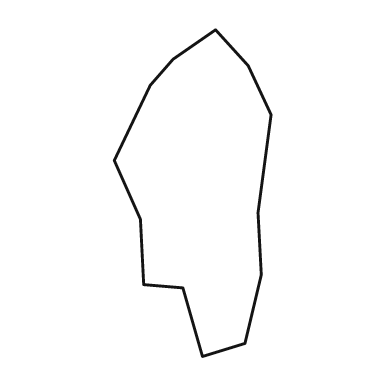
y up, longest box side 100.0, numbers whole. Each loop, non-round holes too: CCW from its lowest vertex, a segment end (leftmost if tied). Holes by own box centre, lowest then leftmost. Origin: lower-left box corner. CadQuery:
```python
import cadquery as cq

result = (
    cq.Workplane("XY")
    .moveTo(27.0, 0.0)
    .lineTo(40.0, 4.0)
    .lineTo(45.0, 25.0)
    .lineTo(44.0, 44.0)
    .lineTo(48.0, 74.0)
    .lineTo(41.0, 89.0)
    .lineTo(31.0, 100.0)
    .lineTo(18.0, 91.0)
    .lineTo(11.0, 83.0)
    .lineTo(0.0, 60.0)
    .lineTo(8.0, 42.0)
    .lineTo(9.0, 22.0)
    .lineTo(21.0, 21.0)
    .close()
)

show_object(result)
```